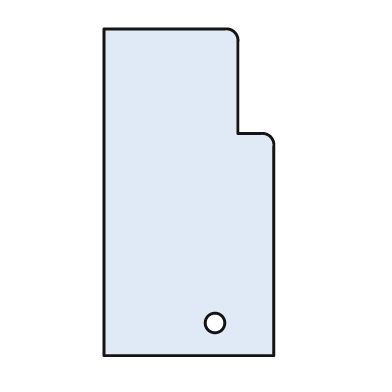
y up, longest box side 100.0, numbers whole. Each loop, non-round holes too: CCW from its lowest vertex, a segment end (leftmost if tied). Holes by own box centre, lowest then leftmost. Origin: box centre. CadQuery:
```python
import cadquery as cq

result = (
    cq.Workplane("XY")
    .moveTo(-26.0, -50.0)
    .lineTo(26.0, -50.0)
    .lineTo(26.0, 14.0)
    .threePointArc((25.0, 17.0), (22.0, 18.0))
    .lineTo(15.0, 18.0)
    .lineTo(15.0, 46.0)
    .threePointArc((14.0, 49.0), (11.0, 50.0))
    .lineTo(-26.0, 50.0)
    .close()
    .moveTo(8.0, -40.0)
    .circle(3.0)
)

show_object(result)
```